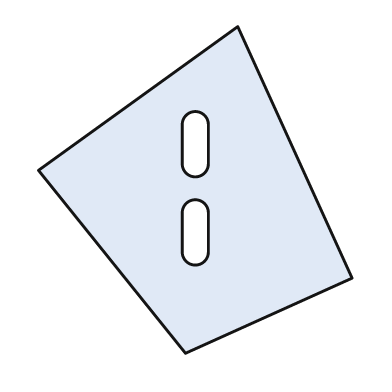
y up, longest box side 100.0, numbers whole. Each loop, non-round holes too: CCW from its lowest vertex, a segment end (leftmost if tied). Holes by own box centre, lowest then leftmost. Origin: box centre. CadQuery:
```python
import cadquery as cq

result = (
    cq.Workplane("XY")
    .moveTo(-3.0, -50.0)
    .lineTo(48.0, -27.0)
    .lineTo(13.0, 50.0)
    .lineTo(-48.0, 6.0)
    .close()
    .moveTo(-4.0, -19.0)
    .threePointArc((0.0, -23.0), (4.0, -19.0))
    .lineTo(4.0, -7.0)
    .threePointArc((0.0, -3.0), (-4.0, -7.0))
    .close()
    .moveTo(-4.0, 8.0)
    .threePointArc((0.0, 4.0), (4.0, 8.0))
    .lineTo(4.0, 20.0)
    .threePointArc((0.0, 24.0), (-4.0, 20.0))
    .close()
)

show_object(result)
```